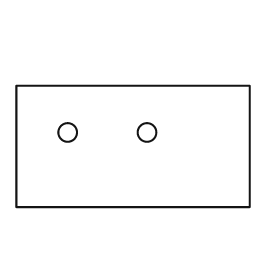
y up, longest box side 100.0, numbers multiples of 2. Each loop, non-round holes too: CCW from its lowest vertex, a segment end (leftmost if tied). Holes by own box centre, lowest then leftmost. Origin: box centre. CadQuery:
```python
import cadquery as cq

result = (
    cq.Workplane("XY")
    .moveTo(-50.0, -26.0)
    .lineTo(50.0, -26.0)
    .lineTo(50.0, 26.0)
    .lineTo(-50.0, 26.0)
    .close()
    .moveTo(-28.0, 6.0)
    .circle(4.0)
    .moveTo(6.0, 6.0)
    .circle(4.0)
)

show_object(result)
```